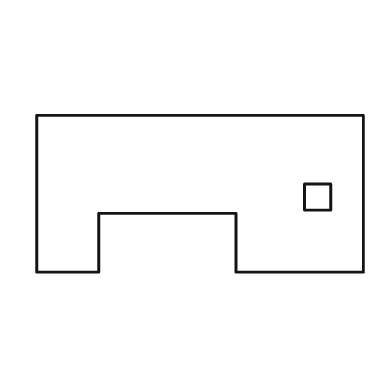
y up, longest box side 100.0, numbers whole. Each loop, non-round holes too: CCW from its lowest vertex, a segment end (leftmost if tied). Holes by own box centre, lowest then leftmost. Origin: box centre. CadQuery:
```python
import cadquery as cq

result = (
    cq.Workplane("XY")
    .moveTo(-50.0, -24.0)
    .lineTo(-31.0, -24.0)
    .lineTo(-31.0, -6.0)
    .lineTo(11.0, -6.0)
    .lineTo(11.0, -24.0)
    .lineTo(50.0, -24.0)
    .lineTo(50.0, 24.0)
    .lineTo(-50.0, 24.0)
    .close()
    .moveTo(32.0, -5.0)
    .lineTo(40.0, -5.0)
    .lineTo(40.0, 3.0)
    .lineTo(32.0, 3.0)
    .close()
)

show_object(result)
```